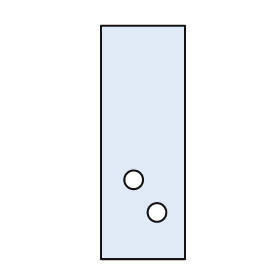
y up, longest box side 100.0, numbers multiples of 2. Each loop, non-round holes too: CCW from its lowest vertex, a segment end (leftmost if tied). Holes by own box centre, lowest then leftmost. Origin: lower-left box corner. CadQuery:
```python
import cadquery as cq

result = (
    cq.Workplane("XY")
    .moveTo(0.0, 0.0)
    .lineTo(36.0, 0.0)
    .lineTo(36.0, 100.0)
    .lineTo(0.0, 100.0)
    .close()
    .moveTo(24.0, 20.0)
    .circle(4.0)
    .moveTo(14.0, 34.0)
    .circle(4.0)
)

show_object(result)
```